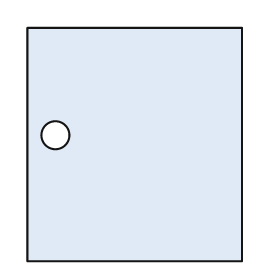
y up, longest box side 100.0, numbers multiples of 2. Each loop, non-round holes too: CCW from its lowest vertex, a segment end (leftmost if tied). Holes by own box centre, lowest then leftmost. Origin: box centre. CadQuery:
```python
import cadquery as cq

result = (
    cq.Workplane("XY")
    .moveTo(-46.0, -50.0)
    .lineTo(46.0, -50.0)
    .lineTo(46.0, 50.0)
    .lineTo(-46.0, 50.0)
    .close()
    .moveTo(-34.0, 4.0)
    .circle(6.0)
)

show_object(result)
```